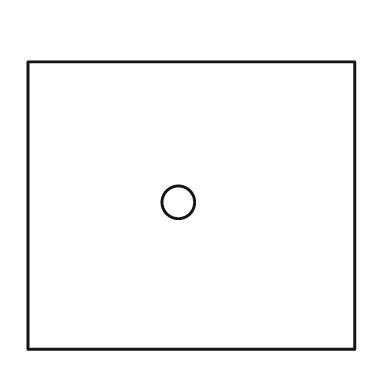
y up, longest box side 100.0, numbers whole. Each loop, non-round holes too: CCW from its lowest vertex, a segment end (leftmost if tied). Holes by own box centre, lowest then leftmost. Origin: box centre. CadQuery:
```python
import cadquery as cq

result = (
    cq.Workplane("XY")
    .moveTo(-50.0, -44.0)
    .lineTo(50.0, -44.0)
    .lineTo(50.0, 44.0)
    .lineTo(-50.0, 44.0)
    .close()
    .moveTo(-4.0, 1.0)
    .circle(5.0)
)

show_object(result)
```